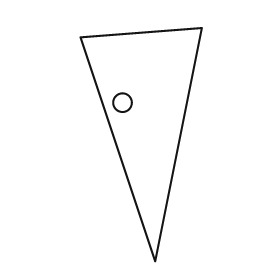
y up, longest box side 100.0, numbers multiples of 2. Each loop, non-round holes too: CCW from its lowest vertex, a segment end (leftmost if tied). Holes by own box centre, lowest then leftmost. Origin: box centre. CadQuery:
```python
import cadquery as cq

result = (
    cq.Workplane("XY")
    .moveTo(6.0, -50.0)
    .lineTo(26.0, 50.0)
    .lineTo(-26.0, 46.0)
    .close()
    .moveTo(-8.0, 18.0)
    .circle(4.0)
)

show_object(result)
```